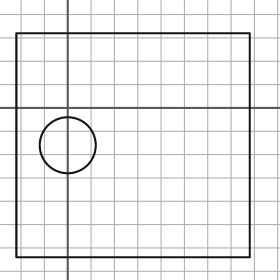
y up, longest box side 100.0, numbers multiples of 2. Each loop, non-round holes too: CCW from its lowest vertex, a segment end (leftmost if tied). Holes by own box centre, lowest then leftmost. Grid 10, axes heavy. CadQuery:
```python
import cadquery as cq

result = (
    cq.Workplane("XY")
    .moveTo(-22.0, -64.0)
    .lineTo(78.0, -64.0)
    .lineTo(78.0, 32.0)
    .lineTo(-22.0, 32.0)
    .close()
    .moveTo(0.0, -16.0)
    .circle(12.0)
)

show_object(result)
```